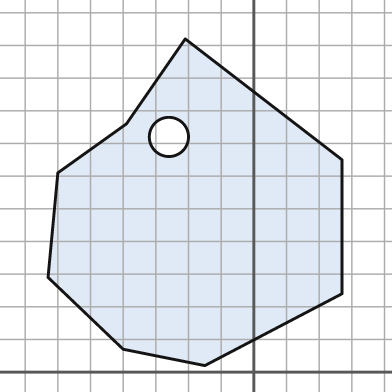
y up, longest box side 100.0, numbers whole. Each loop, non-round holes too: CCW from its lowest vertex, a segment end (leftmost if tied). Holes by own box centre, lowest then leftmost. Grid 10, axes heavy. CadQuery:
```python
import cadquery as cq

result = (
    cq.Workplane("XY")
    .moveTo(-15.0, 2.0)
    .lineTo(27.0, 24.0)
    .lineTo(27.0, 65.0)
    .lineTo(-21.0, 102.0)
    .lineTo(-39.0, 76.0)
    .lineTo(-60.0, 61.0)
    .lineTo(-63.0, 29.0)
    .lineTo(-40.0, 7.0)
    .close()
    .moveTo(-26.0, 72.0)
    .circle(6.0)
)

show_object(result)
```